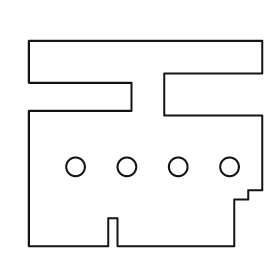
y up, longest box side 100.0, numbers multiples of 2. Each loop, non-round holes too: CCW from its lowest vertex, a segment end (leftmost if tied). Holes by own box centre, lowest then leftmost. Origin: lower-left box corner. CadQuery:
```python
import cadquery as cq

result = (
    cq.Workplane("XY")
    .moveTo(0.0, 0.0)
    .lineTo(34.0, 0.0)
    .lineTo(34.0, 12.0)
    .lineTo(38.0, 12.0)
    .lineTo(38.0, 0.0)
    .lineTo(88.0, 0.0)
    .lineTo(88.0, 20.0)
    .lineTo(94.0, 20.0)
    .lineTo(94.0, 24.0)
    .lineTo(100.0, 24.0)
    .lineTo(100.0, 56.0)
    .lineTo(58.0, 56.0)
    .lineTo(58.0, 74.0)
    .lineTo(100.0, 74.0)
    .lineTo(100.0, 88.0)
    .lineTo(0.0, 88.0)
    .lineTo(0.0, 70.0)
    .lineTo(44.0, 70.0)
    .lineTo(44.0, 58.0)
    .lineTo(0.0, 58.0)
    .close()
    .moveTo(20.0, 34.0)
    .circle(4.0)
    .moveTo(42.0, 34.0)
    .circle(4.0)
    .moveTo(64.0, 34.0)
    .circle(4.0)
    .moveTo(86.0, 34.0)
    .circle(4.0)
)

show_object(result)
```